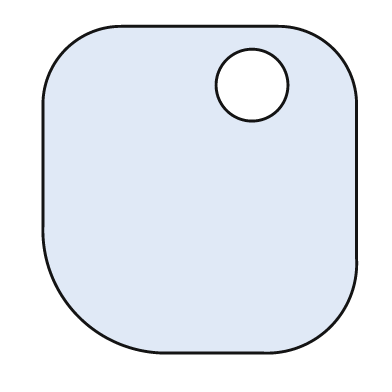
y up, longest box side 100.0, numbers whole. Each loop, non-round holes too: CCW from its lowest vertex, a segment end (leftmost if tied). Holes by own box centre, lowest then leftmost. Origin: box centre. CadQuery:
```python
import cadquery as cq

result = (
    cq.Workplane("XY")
    .moveTo(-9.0, -50.0)
    .lineTo(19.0, -50.0)
    .threePointArc((40.0, -42.0), (48.0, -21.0))
    .lineTo(48.0, 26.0)
    .threePointArc((41.0, 43.0), (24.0, 50.0))
    .lineTo(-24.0, 50.0)
    .threePointArc((-41.0, 43.0), (-48.0, 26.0))
    .lineTo(-48.0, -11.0)
    .threePointArc((-37.0, -39.0), (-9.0, -50.0))
    .close()
    .moveTo(16.0, 32.0)
    .circle(11.0)
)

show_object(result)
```